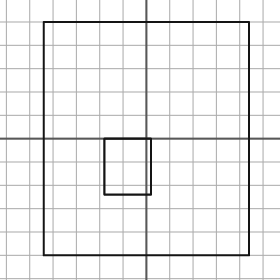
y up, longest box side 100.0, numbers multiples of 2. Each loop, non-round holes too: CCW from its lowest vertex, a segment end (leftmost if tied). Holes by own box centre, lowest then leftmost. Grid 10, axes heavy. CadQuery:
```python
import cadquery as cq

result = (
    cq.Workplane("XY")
    .moveTo(-44.0, -50.0)
    .lineTo(44.0, -50.0)
    .lineTo(44.0, 50.0)
    .lineTo(-44.0, 50.0)
    .close()
    .moveTo(-18.0, -24.0)
    .lineTo(2.0, -24.0)
    .lineTo(2.0, 0.0)
    .lineTo(-18.0, 0.0)
    .close()
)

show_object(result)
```